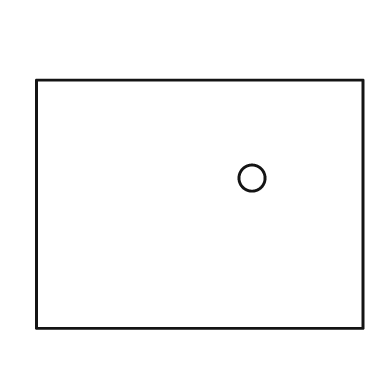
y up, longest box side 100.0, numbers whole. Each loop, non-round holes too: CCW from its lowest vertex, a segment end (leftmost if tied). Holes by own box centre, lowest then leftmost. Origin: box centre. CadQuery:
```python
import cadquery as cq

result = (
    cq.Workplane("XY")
    .moveTo(-50.0, -38.0)
    .lineTo(50.0, -38.0)
    .lineTo(50.0, 38.0)
    .lineTo(-50.0, 38.0)
    .close()
    .moveTo(16.0, 8.0)
    .circle(4.0)
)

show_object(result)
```